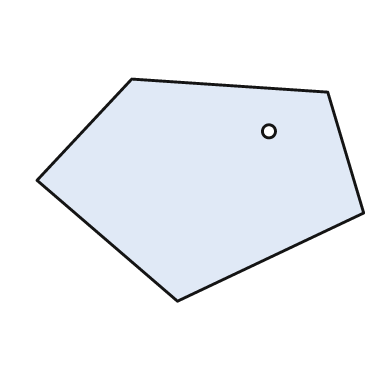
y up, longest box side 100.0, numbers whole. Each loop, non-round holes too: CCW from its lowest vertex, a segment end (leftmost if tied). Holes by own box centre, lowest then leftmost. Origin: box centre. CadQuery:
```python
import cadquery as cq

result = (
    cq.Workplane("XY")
    .moveTo(-7.0, -34.0)
    .lineTo(50.0, -7.0)
    .lineTo(39.0, 30.0)
    .lineTo(-21.0, 34.0)
    .lineTo(-50.0, 3.0)
    .close()
    .moveTo(21.0, 18.0)
    .circle(2.0)
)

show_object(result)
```